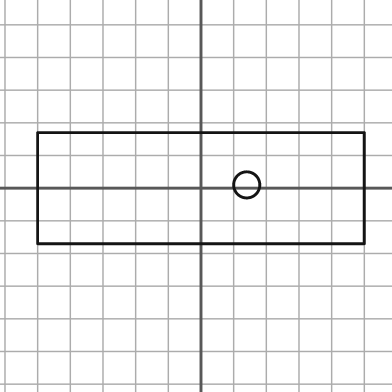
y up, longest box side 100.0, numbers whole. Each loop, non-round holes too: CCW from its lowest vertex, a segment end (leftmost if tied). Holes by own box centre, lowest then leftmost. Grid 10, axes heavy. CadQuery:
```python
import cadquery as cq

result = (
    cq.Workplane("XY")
    .moveTo(-50.0, -17.0)
    .lineTo(50.0, -17.0)
    .lineTo(50.0, 17.0)
    .lineTo(-50.0, 17.0)
    .close()
    .moveTo(14.0, 1.0)
    .circle(4.0)
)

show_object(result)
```